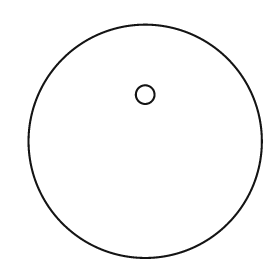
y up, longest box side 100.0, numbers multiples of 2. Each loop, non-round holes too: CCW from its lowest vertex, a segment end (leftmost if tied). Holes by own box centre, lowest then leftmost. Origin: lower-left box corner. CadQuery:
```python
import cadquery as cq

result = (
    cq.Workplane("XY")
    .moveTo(50.0, 50.0)
    .circle(50.0)
    .moveTo(50.0, 70.0)
    .circle(4.0)
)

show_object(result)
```